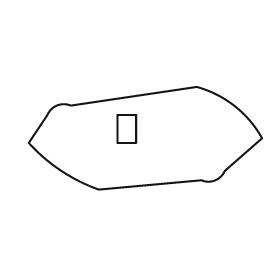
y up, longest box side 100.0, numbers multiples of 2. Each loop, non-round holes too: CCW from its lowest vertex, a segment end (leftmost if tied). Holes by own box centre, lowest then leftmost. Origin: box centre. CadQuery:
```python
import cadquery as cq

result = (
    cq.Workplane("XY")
    .moveTo(-20.0, -22.0)
    .lineTo(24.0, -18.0)
    .threePointArc((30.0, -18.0), (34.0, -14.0))
    .lineTo(50.0, 0.0)
    .threePointArc((38.0, 14.0), (22.0, 22.0))
    .lineTo(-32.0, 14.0)
    .threePointArc((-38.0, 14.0), (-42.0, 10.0))
    .lineTo(-50.0, -2.0)
    .threePointArc((-36.0, -14.0), (-20.0, -22.0))
    .close()
    .moveTo(-12.0, -2.0)
    .lineTo(-4.0, -2.0)
    .lineTo(-4.0, 10.0)
    .lineTo(-12.0, 10.0)
    .close()
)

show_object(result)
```